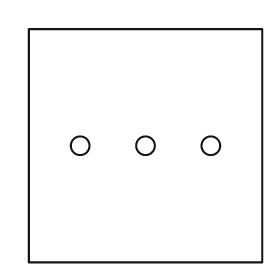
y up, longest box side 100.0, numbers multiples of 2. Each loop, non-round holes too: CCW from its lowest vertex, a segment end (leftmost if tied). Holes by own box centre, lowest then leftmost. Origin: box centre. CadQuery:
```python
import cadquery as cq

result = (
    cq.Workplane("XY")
    .moveTo(-50.0, -50.0)
    .lineTo(50.0, -50.0)
    .lineTo(50.0, 50.0)
    .lineTo(-50.0, 50.0)
    .close()
    .moveTo(-28.0, 0.0)
    .circle(4.0)
    .moveTo(0.0, 0.0)
    .circle(4.0)
    .moveTo(28.0, 0.0)
    .circle(4.0)
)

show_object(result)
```